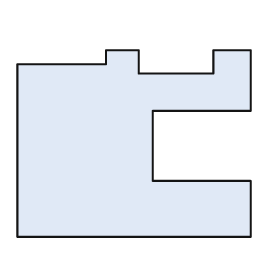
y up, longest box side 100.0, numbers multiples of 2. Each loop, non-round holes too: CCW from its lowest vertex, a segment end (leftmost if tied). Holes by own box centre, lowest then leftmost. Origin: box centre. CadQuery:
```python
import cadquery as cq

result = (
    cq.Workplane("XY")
    .moveTo(-50.0, -40.0)
    .lineTo(50.0, -40.0)
    .lineTo(50.0, -16.0)
    .lineTo(8.0, -16.0)
    .lineTo(8.0, 14.0)
    .lineTo(50.0, 14.0)
    .lineTo(50.0, 40.0)
    .lineTo(34.0, 40.0)
    .lineTo(34.0, 30.0)
    .lineTo(2.0, 30.0)
    .lineTo(2.0, 40.0)
    .lineTo(-12.0, 40.0)
    .lineTo(-12.0, 34.0)
    .lineTo(-50.0, 34.0)
    .close()
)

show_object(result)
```